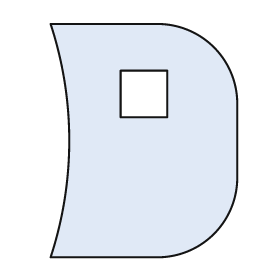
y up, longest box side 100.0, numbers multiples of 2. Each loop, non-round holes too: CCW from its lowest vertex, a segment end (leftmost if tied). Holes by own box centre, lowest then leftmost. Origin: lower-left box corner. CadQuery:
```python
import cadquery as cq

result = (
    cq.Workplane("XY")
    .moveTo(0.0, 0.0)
    .lineTo(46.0, 0.0)
    .threePointArc((70.0, 10.0), (80.0, 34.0))
    .lineTo(80.0, 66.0)
    .threePointArc((70.0, 90.0), (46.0, 100.0))
    .lineTo(0.0, 100.0)
    .threePointArc((8.0, 50.0), (0.0, 0.0))
    .close()
    .moveTo(30.0, 60.0)
    .lineTo(50.0, 60.0)
    .lineTo(50.0, 80.0)
    .lineTo(30.0, 80.0)
    .close()
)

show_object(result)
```